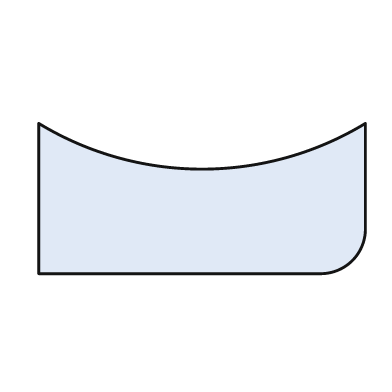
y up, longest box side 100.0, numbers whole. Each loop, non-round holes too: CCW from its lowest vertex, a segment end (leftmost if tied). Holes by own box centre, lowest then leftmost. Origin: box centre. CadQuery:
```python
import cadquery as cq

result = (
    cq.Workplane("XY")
    .moveTo(-50.0, -23.0)
    .lineTo(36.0, -23.0)
    .threePointArc((46.0, -19.0), (50.0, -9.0))
    .lineTo(50.0, 23.0)
    .threePointArc((0.0, 9.0), (-50.0, 23.0))
    .close()
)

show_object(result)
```